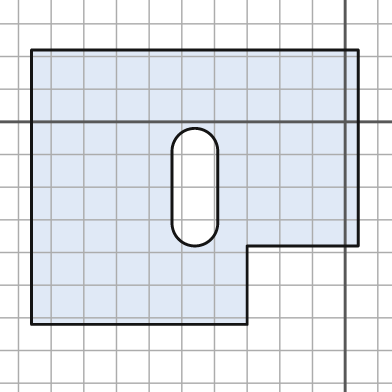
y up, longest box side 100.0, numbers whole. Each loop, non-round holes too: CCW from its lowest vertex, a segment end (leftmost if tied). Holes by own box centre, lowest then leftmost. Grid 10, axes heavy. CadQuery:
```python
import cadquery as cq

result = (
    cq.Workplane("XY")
    .moveTo(-96.0, -62.0)
    .lineTo(-30.0, -62.0)
    .lineTo(-30.0, -38.0)
    .lineTo(4.0, -38.0)
    .lineTo(4.0, 22.0)
    .lineTo(-96.0, 22.0)
    .close()
    .moveTo(-53.0, -31.0)
    .threePointArc((-46.0, -38.0), (-39.0, -31.0))
    .lineTo(-39.0, -9.0)
    .threePointArc((-46.0, -2.0), (-53.0, -9.0))
    .close()
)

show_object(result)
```